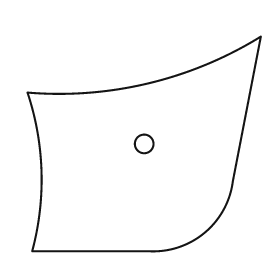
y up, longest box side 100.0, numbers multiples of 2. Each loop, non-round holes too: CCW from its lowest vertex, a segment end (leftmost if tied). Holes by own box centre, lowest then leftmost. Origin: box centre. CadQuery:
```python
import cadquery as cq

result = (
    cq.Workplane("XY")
    .moveTo(-48.0, -46.0)
    .lineTo(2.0, -46.0)
    .threePointArc((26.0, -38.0), (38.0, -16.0))
    .lineTo(50.0, 46.0)
    .threePointArc((2.0, 26.0), (-50.0, 22.0))
    .threePointArc((-44.0, -12.0), (-48.0, -46.0))
    .close()
    .moveTo(0.0, 0.0)
    .circle(4.0)
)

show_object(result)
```